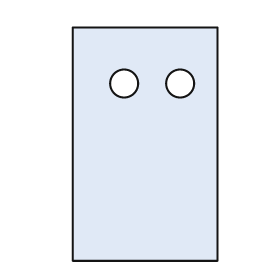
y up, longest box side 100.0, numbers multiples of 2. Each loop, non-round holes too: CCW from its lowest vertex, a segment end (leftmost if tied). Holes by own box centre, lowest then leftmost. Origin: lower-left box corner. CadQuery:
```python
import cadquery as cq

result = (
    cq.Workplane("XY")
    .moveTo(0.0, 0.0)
    .lineTo(62.0, 0.0)
    .lineTo(62.0, 100.0)
    .lineTo(0.0, 100.0)
    .close()
    .moveTo(22.0, 76.0)
    .circle(6.0)
    .moveTo(46.0, 76.0)
    .circle(6.0)
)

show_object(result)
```